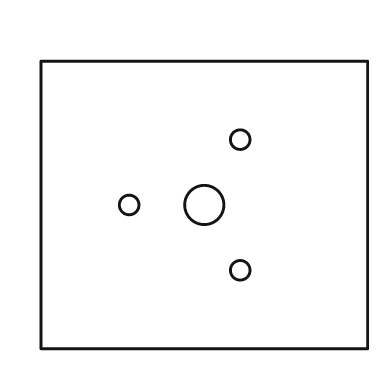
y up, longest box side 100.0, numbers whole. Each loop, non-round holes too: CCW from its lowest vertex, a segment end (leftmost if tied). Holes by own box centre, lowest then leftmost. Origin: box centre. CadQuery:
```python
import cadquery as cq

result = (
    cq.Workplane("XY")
    .moveTo(-50.0, -44.0)
    .lineTo(50.0, -44.0)
    .lineTo(50.0, 44.0)
    .lineTo(-50.0, 44.0)
    .close()
    .moveTo(11.0, -20.0)
    .circle(3.0)
    .moveTo(-23.0, 0.0)
    .circle(3.0)
    .moveTo(0.0, 0.0)
    .circle(6.0)
    .moveTo(11.0, 20.0)
    .circle(3.0)
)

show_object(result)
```